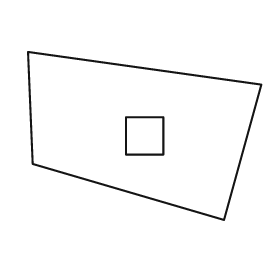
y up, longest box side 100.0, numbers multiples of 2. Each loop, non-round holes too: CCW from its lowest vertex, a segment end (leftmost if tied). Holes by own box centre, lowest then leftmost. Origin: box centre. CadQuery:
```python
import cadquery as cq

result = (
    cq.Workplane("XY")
    .moveTo(34.0, -36.0)
    .lineTo(50.0, 22.0)
    .lineTo(-50.0, 36.0)
    .lineTo(-48.0, -12.0)
    .close()
    .moveTo(-8.0, -8.0)
    .lineTo(8.0, -8.0)
    .lineTo(8.0, 8.0)
    .lineTo(-8.0, 8.0)
    .close()
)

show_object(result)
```